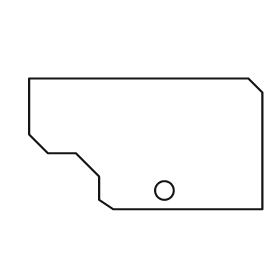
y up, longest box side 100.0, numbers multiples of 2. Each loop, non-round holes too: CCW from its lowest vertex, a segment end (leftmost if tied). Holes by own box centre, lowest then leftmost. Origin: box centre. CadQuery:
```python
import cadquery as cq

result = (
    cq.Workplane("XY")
    .moveTo(-14.0, -28.0)
    .lineTo(50.0, -28.0)
    .lineTo(50.0, 22.0)
    .lineTo(44.0, 28.0)
    .lineTo(-50.0, 28.0)
    .lineTo(-50.0, 4.0)
    .lineTo(-42.0, -4.0)
    .lineTo(-30.0, -4.0)
    .lineTo(-20.0, -14.0)
    .lineTo(-20.0, -24.0)
    .close()
    .moveTo(8.0, -20.0)
    .circle(4.0)
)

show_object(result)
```